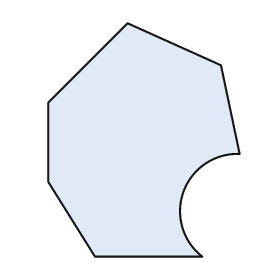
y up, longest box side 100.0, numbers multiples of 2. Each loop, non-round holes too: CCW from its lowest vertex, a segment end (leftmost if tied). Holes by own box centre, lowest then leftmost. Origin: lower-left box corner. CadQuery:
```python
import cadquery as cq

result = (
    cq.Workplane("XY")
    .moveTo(20.0, 0.0)
    .lineTo(66.0, 0.0)
    .threePointArc((58.0, 28.0), (82.0, 44.0))
    .lineTo(74.0, 82.0)
    .lineTo(34.0, 100.0)
    .lineTo(0.0, 66.0)
    .lineTo(0.0, 32.0)
    .close()
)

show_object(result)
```